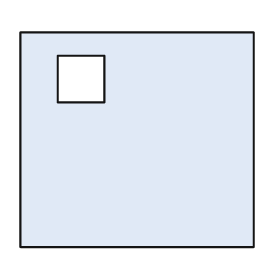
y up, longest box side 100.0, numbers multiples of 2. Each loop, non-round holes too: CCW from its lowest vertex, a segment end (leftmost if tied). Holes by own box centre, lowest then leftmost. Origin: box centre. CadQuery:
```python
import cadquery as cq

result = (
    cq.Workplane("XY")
    .moveTo(-50.0, -46.0)
    .lineTo(50.0, -46.0)
    .lineTo(50.0, 46.0)
    .lineTo(-50.0, 46.0)
    .close()
    .moveTo(-34.0, 16.0)
    .lineTo(-14.0, 16.0)
    .lineTo(-14.0, 36.0)
    .lineTo(-34.0, 36.0)
    .close()
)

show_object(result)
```